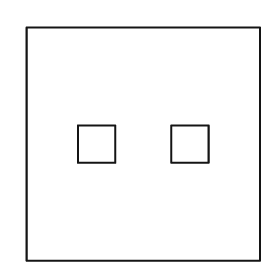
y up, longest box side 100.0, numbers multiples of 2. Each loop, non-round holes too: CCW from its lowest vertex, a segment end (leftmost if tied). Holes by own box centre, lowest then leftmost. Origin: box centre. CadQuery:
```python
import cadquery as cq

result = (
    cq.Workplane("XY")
    .moveTo(-50.0, -50.0)
    .lineTo(50.0, -50.0)
    .lineTo(50.0, 50.0)
    .lineTo(-50.0, 50.0)
    .close()
    .moveTo(-28.0, -8.0)
    .lineTo(-12.0, -8.0)
    .lineTo(-12.0, 8.0)
    .lineTo(-28.0, 8.0)
    .close()
    .moveTo(12.0, -8.0)
    .lineTo(28.0, -8.0)
    .lineTo(28.0, 8.0)
    .lineTo(12.0, 8.0)
    .close()
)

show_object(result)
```